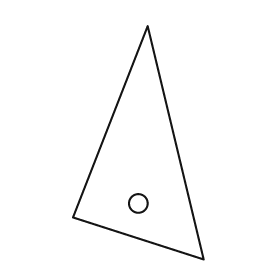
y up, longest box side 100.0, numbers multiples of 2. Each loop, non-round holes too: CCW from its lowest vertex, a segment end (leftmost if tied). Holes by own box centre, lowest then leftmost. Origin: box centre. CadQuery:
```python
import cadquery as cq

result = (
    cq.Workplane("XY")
    .moveTo(28.0, -50.0)
    .lineTo(4.0, 50.0)
    .lineTo(-28.0, -32.0)
    .close()
    .moveTo(0.0, -26.0)
    .circle(4.0)
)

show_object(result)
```